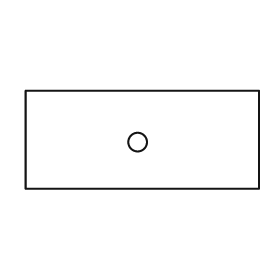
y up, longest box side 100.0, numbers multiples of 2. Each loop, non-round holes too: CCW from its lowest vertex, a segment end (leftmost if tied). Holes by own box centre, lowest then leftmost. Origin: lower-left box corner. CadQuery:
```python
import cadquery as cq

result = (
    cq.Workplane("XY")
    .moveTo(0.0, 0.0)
    .lineTo(100.0, 0.0)
    .lineTo(100.0, 42.0)
    .lineTo(0.0, 42.0)
    .close()
    .moveTo(48.0, 20.0)
    .circle(4.0)
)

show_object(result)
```